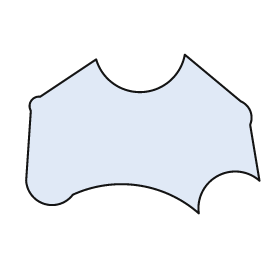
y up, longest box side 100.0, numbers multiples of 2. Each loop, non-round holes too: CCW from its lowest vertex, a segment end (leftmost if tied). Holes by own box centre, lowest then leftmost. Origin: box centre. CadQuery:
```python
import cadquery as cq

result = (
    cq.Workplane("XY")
    .moveTo(24.0, -34.0)
    .threePointArc((32.0, -18.0), (50.0, -20.0))
    .lineTo(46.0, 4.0)
    .threePointArc((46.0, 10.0), (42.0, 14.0))
    .lineTo(18.0, 34.0)
    .threePointArc((0.0, 18.0), (-20.0, 32.0))
    .lineTo(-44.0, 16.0)
    .threePointArc((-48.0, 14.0), (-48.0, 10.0))
    .lineTo(-50.0, -20.0)
    .threePointArc((-42.0, -30.0), (-30.0, -26.0))
    .threePointArc((-2.0, -22.0), (24.0, -34.0))
    .close()
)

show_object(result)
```